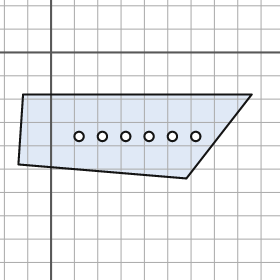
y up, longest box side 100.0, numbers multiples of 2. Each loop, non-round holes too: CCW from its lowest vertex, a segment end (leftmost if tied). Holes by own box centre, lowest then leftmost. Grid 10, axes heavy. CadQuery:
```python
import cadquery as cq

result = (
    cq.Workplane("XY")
    .moveTo(58.0, -54.0)
    .lineTo(86.0, -18.0)
    .lineTo(-12.0, -18.0)
    .lineTo(-14.0, -48.0)
    .close()
    .moveTo(12.0, -36.0)
    .circle(2.0)
    .moveTo(22.0, -36.0)
    .circle(2.0)
    .moveTo(32.0, -36.0)
    .circle(2.0)
    .moveTo(42.0, -36.0)
    .circle(2.0)
    .moveTo(52.0, -36.0)
    .circle(2.0)
    .moveTo(62.0, -36.0)
    .circle(2.0)
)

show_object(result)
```